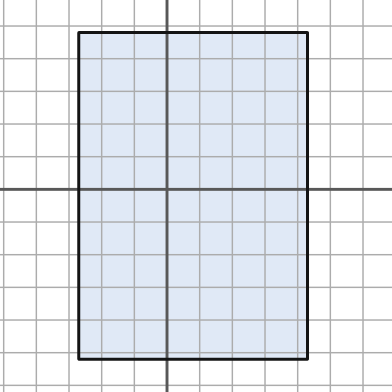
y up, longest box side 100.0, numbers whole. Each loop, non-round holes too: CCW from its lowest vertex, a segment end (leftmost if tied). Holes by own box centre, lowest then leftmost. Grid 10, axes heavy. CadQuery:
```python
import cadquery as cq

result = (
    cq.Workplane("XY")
    .moveTo(-27.0, -52.0)
    .lineTo(43.0, -52.0)
    .lineTo(43.0, 48.0)
    .lineTo(-27.0, 48.0)
    .close()
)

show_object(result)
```